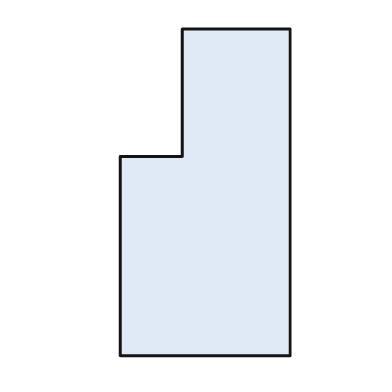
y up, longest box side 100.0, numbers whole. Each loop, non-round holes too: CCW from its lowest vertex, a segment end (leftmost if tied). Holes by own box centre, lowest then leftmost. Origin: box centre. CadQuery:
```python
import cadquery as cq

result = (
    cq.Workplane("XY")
    .moveTo(-26.0, -50.0)
    .lineTo(26.0, -50.0)
    .lineTo(26.0, 50.0)
    .lineTo(-7.0, 50.0)
    .lineTo(-7.0, 11.0)
    .lineTo(-26.0, 11.0)
    .close()
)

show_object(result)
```